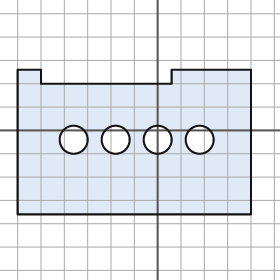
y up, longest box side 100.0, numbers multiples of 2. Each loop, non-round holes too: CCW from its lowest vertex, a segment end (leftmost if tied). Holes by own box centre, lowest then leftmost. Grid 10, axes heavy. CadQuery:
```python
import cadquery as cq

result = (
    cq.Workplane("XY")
    .moveTo(-60.0, -36.0)
    .lineTo(40.0, -36.0)
    .lineTo(40.0, 26.0)
    .lineTo(6.0, 26.0)
    .lineTo(6.0, 20.0)
    .lineTo(-50.0, 20.0)
    .lineTo(-50.0, 26.0)
    .lineTo(-60.0, 26.0)
    .close()
    .moveTo(-36.0, -4.0)
    .circle(6.0)
    .moveTo(-18.0, -4.0)
    .circle(6.0)
    .moveTo(0.0, -4.0)
    .circle(6.0)
    .moveTo(18.0, -4.0)
    .circle(6.0)
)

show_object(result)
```